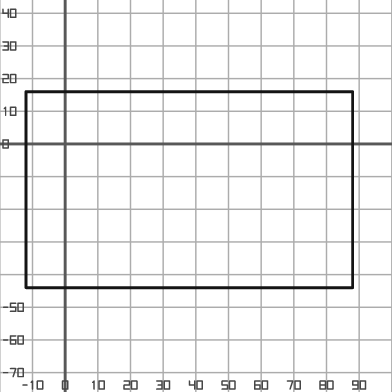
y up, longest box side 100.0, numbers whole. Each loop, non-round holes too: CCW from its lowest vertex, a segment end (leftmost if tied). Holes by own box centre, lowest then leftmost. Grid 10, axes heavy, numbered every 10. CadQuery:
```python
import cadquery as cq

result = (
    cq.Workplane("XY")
    .moveTo(-12.0, -44.0)
    .lineTo(88.0, -44.0)
    .lineTo(88.0, 16.0)
    .lineTo(-12.0, 16.0)
    .close()
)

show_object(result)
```